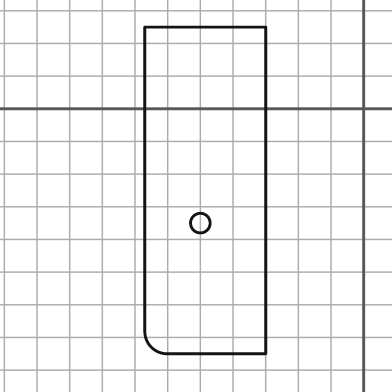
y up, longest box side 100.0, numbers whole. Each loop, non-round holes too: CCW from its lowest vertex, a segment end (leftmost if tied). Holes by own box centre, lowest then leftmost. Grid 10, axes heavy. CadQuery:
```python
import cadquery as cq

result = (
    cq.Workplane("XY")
    .moveTo(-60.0, -75.0)
    .lineTo(-30.0, -75.0)
    .lineTo(-30.0, 25.0)
    .lineTo(-67.0, 25.0)
    .lineTo(-67.0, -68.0)
    .threePointArc((-65.0, -73.0), (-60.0, -75.0))
    .close()
    .moveTo(-50.0, -35.0)
    .circle(3.0)
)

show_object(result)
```